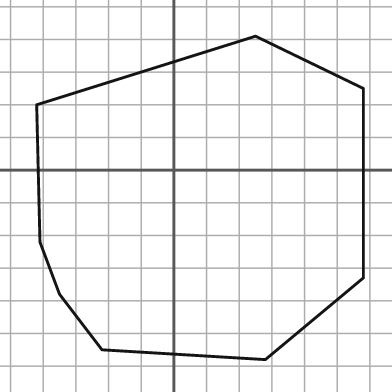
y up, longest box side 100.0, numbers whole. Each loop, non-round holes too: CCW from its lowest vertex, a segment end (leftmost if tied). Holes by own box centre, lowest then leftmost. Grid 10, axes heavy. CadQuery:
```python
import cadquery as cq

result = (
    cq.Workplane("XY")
    .moveTo(28.0, -58.0)
    .lineTo(58.0, -33.0)
    .lineTo(58.0, 25.0)
    .lineTo(25.0, 41.0)
    .lineTo(-42.0, 20.0)
    .lineTo(-41.0, -22.0)
    .lineTo(-35.0, -38.0)
    .lineTo(-22.0, -55.0)
    .close()
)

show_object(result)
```